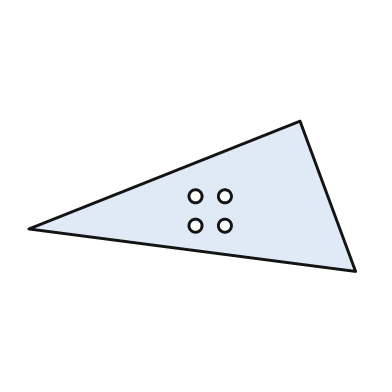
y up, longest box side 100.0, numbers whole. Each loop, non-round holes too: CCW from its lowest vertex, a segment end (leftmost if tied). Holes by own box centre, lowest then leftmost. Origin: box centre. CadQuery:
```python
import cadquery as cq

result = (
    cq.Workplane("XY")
    .moveTo(50.0, -23.0)
    .lineTo(33.0, 23.0)
    .lineTo(-50.0, -10.0)
    .close()
    .moveTo(1.0, -9.0)
    .circle(2.0)
    .moveTo(10.0, -9.0)
    .circle(2.0)
    .moveTo(1.0, 0.0)
    .circle(2.0)
    .moveTo(10.0, 0.0)
    .circle(2.0)
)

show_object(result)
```